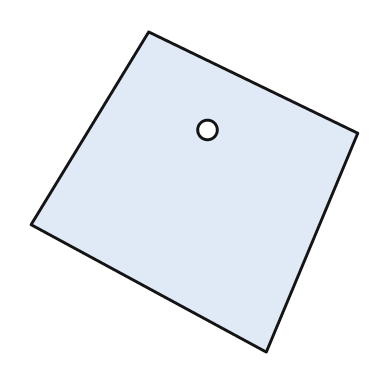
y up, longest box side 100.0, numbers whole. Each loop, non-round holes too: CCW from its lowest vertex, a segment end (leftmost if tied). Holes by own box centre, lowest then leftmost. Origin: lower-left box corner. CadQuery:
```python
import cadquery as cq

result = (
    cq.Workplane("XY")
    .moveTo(72.0, 0.0)
    .lineTo(100.0, 67.0)
    .lineTo(36.0, 98.0)
    .lineTo(0.0, 39.0)
    .close()
    .moveTo(54.0, 68.0)
    .circle(3.0)
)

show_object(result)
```